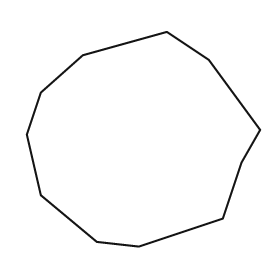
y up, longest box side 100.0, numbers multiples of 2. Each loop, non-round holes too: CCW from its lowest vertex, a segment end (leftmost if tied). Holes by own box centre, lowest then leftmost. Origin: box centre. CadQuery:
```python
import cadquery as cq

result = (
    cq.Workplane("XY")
    .moveTo(-2.0, -46.0)
    .lineTo(34.0, -34.0)
    .lineTo(42.0, -10.0)
    .lineTo(50.0, 4.0)
    .lineTo(28.0, 34.0)
    .lineTo(10.0, 46.0)
    .lineTo(-26.0, 36.0)
    .lineTo(-44.0, 20.0)
    .lineTo(-50.0, 2.0)
    .lineTo(-44.0, -24.0)
    .lineTo(-20.0, -44.0)
    .close()
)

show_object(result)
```